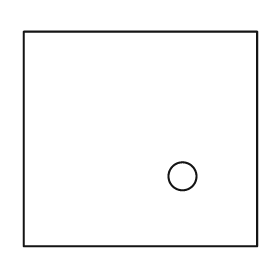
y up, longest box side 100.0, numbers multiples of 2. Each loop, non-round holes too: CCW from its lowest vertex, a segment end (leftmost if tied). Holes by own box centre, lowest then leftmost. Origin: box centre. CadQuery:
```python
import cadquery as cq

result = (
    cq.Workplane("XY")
    .moveTo(-50.0, -46.0)
    .lineTo(50.0, -46.0)
    .lineTo(50.0, 46.0)
    .lineTo(-50.0, 46.0)
    .close()
    .moveTo(18.0, -16.0)
    .circle(6.0)
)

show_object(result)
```